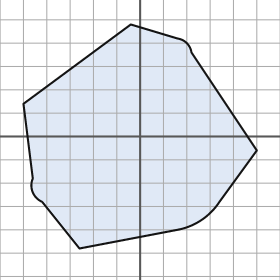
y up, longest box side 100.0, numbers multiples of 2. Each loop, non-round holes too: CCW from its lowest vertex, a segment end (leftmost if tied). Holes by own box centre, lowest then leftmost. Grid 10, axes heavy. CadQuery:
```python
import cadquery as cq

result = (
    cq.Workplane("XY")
    .moveTo(-26.0, -48.0)
    .lineTo(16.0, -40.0)
    .threePointArc((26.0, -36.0), (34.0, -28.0))
    .lineTo(50.0, -6.0)
    .lineTo(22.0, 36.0)
    .threePointArc((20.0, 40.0), (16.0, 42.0))
    .lineTo(-4.0, 48.0)
    .lineTo(-50.0, 14.0)
    .lineTo(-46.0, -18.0)
    .threePointArc((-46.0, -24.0), (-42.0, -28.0))
    .close()
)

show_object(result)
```